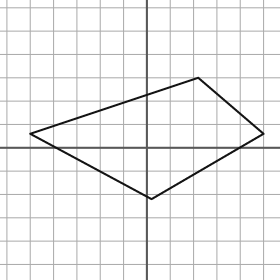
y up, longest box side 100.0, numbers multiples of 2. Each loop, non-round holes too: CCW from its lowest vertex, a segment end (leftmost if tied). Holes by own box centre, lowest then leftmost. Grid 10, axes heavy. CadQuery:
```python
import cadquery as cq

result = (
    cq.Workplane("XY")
    .moveTo(2.0, -22.0)
    .lineTo(50.0, 6.0)
    .lineTo(22.0, 30.0)
    .lineTo(-50.0, 6.0)
    .close()
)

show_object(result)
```